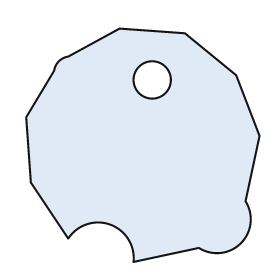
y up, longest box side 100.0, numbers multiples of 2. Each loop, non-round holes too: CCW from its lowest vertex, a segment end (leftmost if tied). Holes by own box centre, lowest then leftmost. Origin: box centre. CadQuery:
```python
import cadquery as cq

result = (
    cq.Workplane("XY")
    .moveTo(-4.0, -50.0)
    .lineTo(24.0, -44.0)
    .threePointArc((42.0, -42.0), (44.0, -24.0))
    .lineTo(50.0, 4.0)
    .lineTo(40.0, 30.0)
    .lineTo(18.0, 48.0)
    .lineTo(-10.0, 50.0)
    .lineTo(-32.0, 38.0)
    .threePointArc((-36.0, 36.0), (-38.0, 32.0))
    .lineTo(-50.0, 12.0)
    .lineTo(-48.0, -16.0)
    .lineTo(-32.0, -40.0)
    .threePointArc((-14.0, -34.0), (-4.0, -50.0))
    .close()
    .moveTo(4.0, 28.0)
    .circle(8.0)
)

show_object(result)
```